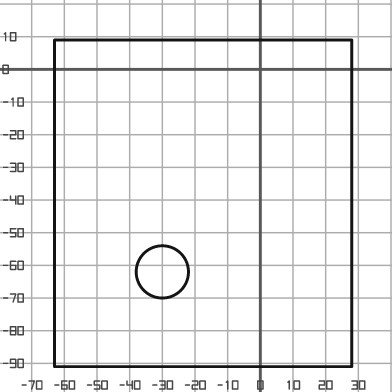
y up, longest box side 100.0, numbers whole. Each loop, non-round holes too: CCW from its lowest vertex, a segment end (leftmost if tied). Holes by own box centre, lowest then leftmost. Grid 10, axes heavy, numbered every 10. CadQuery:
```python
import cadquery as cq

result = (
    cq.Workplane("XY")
    .moveTo(-63.0, -91.0)
    .lineTo(28.0, -91.0)
    .lineTo(28.0, 9.0)
    .lineTo(-63.0, 9.0)
    .close()
    .moveTo(-30.0, -62.0)
    .circle(8.0)
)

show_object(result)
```